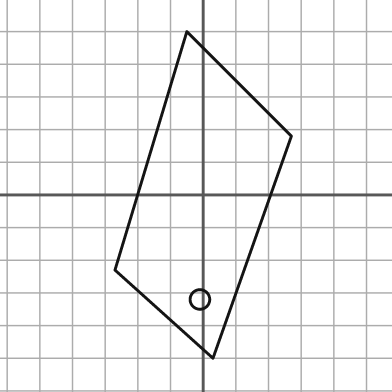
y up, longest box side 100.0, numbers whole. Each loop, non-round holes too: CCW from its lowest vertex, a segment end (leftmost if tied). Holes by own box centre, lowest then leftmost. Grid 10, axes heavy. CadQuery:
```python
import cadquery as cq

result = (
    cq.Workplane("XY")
    .moveTo(3.0, -50.0)
    .lineTo(27.0, 18.0)
    .lineTo(-5.0, 50.0)
    .lineTo(-27.0, -23.0)
    .close()
    .moveTo(-1.0, -32.0)
    .circle(3.0)
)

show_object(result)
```